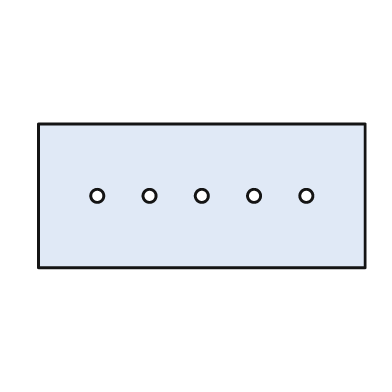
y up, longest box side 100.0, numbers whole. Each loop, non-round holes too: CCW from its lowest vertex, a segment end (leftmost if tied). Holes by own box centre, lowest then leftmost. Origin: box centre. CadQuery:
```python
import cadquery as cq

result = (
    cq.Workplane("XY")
    .moveTo(-50.0, -22.0)
    .lineTo(50.0, -22.0)
    .lineTo(50.0, 22.0)
    .lineTo(-50.0, 22.0)
    .close()
    .moveTo(-32.0, 0.0)
    .circle(2.0)
    .moveTo(-16.0, 0.0)
    .circle(2.0)
    .moveTo(0.0, 0.0)
    .circle(2.0)
    .moveTo(16.0, 0.0)
    .circle(2.0)
    .moveTo(32.0, 0.0)
    .circle(2.0)
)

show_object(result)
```